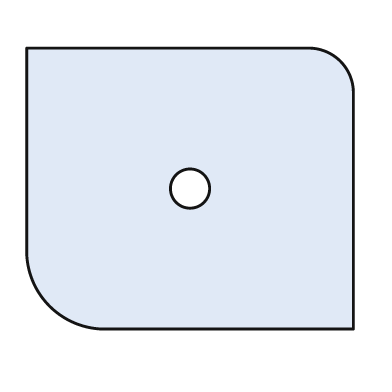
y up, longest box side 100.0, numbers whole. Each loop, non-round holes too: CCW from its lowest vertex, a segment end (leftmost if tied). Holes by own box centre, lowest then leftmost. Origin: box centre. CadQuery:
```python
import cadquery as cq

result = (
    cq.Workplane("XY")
    .moveTo(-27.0, -43.0)
    .lineTo(50.0, -43.0)
    .lineTo(50.0, 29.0)
    .threePointArc((46.0, 39.0), (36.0, 43.0))
    .lineTo(-50.0, 43.0)
    .lineTo(-50.0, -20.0)
    .threePointArc((-43.0, -36.0), (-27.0, -43.0))
    .close()
    .moveTo(0.0, 0.0)
    .circle(6.0)
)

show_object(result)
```